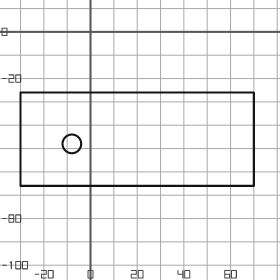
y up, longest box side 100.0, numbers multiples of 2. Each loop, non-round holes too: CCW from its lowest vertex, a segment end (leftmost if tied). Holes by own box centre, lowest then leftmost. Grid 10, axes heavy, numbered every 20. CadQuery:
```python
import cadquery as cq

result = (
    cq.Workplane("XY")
    .moveTo(-30.0, -66.0)
    .lineTo(70.0, -66.0)
    .lineTo(70.0, -26.0)
    .lineTo(-30.0, -26.0)
    .close()
    .moveTo(-8.0, -48.0)
    .circle(4.0)
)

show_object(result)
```